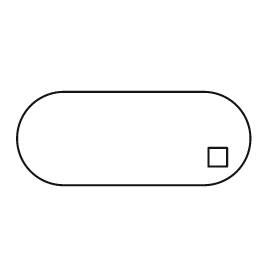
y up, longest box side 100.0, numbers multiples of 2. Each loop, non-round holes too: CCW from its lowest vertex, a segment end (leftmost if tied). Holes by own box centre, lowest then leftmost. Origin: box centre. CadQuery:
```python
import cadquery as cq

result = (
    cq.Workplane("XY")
    .moveTo(-30.0, -20.0)
    .lineTo(30.0, -20.0)
    .threePointArc((50.0, 0.0), (30.0, 20.0))
    .lineTo(-30.0, 20.0)
    .threePointArc((-50.0, 0.0), (-30.0, -20.0))
    .close()
    .moveTo(32.0, -12.0)
    .lineTo(40.0, -12.0)
    .lineTo(40.0, -4.0)
    .lineTo(32.0, -4.0)
    .close()
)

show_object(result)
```